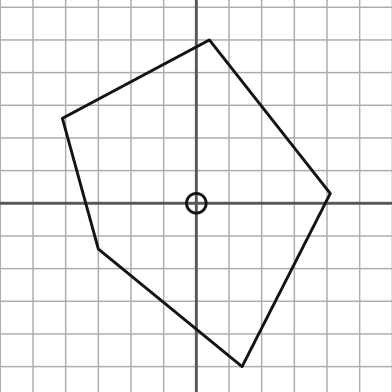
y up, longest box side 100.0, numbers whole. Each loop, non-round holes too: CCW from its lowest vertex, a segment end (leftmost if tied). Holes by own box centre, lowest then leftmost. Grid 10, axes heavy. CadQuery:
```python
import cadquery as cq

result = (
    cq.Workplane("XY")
    .moveTo(14.0, -50.0)
    .lineTo(41.0, 3.0)
    .lineTo(4.0, 50.0)
    .lineTo(-41.0, 26.0)
    .lineTo(-30.0, -14.0)
    .close()
    .moveTo(0.0, 0.0)
    .circle(3.0)
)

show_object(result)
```